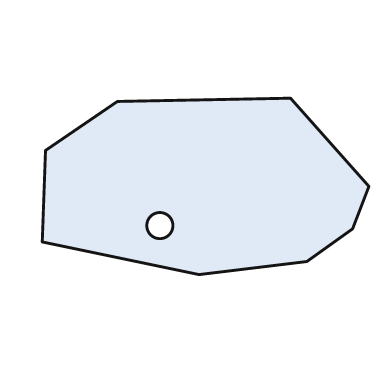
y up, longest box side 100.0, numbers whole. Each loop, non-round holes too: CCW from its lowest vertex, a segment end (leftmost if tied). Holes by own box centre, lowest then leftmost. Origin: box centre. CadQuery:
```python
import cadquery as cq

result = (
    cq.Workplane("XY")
    .moveTo(-2.0, -27.0)
    .lineTo(31.0, -23.0)
    .lineTo(45.0, -13.0)
    .lineTo(50.0, 0.0)
    .lineTo(26.0, 27.0)
    .lineTo(-27.0, 26.0)
    .lineTo(-49.0, 11.0)
    .lineTo(-50.0, -17.0)
    .close()
    .moveTo(-14.0, -12.0)
    .circle(4.0)
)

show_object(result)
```